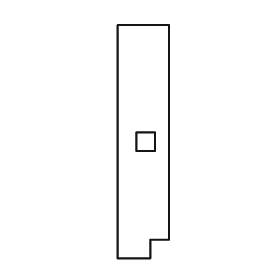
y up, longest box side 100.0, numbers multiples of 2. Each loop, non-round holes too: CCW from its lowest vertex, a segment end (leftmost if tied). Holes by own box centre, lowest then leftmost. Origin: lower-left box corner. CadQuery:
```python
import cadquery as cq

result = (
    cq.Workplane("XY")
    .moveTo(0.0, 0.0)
    .lineTo(14.0, 0.0)
    .lineTo(14.0, 8.0)
    .lineTo(22.0, 8.0)
    .lineTo(22.0, 100.0)
    .lineTo(0.0, 100.0)
    .close()
    .moveTo(8.0, 46.0)
    .lineTo(16.0, 46.0)
    .lineTo(16.0, 54.0)
    .lineTo(8.0, 54.0)
    .close()
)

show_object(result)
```